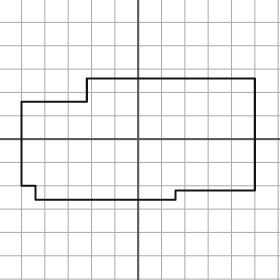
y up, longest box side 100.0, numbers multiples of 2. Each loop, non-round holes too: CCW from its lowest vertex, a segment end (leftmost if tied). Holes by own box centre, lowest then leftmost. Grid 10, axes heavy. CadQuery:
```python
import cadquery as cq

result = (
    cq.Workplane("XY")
    .moveTo(-44.0, -26.0)
    .lineTo(16.0, -26.0)
    .lineTo(16.0, -22.0)
    .lineTo(50.0, -22.0)
    .lineTo(50.0, 26.0)
    .lineTo(-22.0, 26.0)
    .lineTo(-22.0, 16.0)
    .lineTo(-50.0, 16.0)
    .lineTo(-50.0, -20.0)
    .lineTo(-44.0, -20.0)
    .close()
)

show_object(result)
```